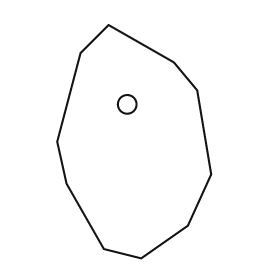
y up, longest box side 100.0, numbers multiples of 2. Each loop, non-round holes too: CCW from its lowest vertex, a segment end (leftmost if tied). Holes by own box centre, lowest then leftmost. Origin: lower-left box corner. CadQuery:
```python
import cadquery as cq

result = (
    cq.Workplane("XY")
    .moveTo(36.0, 0.0)
    .lineTo(56.0, 14.0)
    .lineTo(66.0, 36.0)
    .lineTo(60.0, 72.0)
    .lineTo(50.0, 84.0)
    .lineTo(22.0, 100.0)
    .lineTo(10.0, 88.0)
    .lineTo(0.0, 50.0)
    .lineTo(4.0, 32.0)
    .lineTo(20.0, 4.0)
    .close()
    .moveTo(30.0, 66.0)
    .circle(4.0)
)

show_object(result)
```